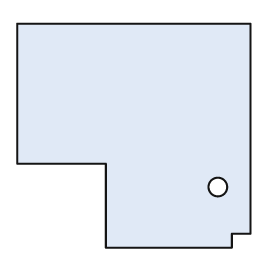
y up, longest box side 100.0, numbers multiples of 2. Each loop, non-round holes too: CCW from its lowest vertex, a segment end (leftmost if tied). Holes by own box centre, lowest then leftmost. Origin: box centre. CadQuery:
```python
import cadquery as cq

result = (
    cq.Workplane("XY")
    .moveTo(-12.0, -48.0)
    .lineTo(42.0, -48.0)
    .lineTo(42.0, -42.0)
    .lineTo(50.0, -42.0)
    .lineTo(50.0, 48.0)
    .lineTo(-50.0, 48.0)
    .lineTo(-50.0, -12.0)
    .lineTo(-12.0, -12.0)
    .close()
    .moveTo(36.0, -22.0)
    .circle(4.0)
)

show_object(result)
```